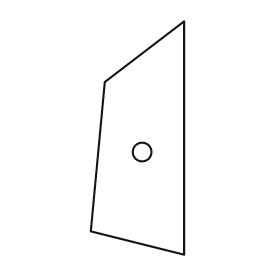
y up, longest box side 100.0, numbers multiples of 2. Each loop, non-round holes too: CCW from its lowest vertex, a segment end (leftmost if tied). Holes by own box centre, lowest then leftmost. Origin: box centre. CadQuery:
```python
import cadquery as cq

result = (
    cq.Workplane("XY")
    .moveTo(20.0, -50.0)
    .lineTo(20.0, 50.0)
    .lineTo(-14.0, 24.0)
    .lineTo(-20.0, -40.0)
    .close()
    .moveTo(2.0, -6.0)
    .circle(4.0)
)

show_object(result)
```